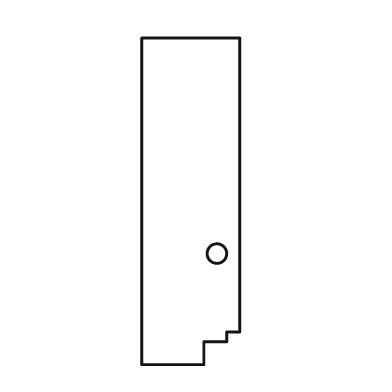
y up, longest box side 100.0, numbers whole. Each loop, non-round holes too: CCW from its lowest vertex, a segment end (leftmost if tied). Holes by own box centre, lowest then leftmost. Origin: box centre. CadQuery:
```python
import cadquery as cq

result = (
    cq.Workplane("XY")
    .moveTo(-15.0, -50.0)
    .lineTo(4.0, -50.0)
    .lineTo(4.0, -43.0)
    .lineTo(11.0, -43.0)
    .lineTo(11.0, -40.0)
    .lineTo(15.0, -40.0)
    .lineTo(15.0, 50.0)
    .lineTo(-15.0, 50.0)
    .close()
    .moveTo(8.0, -16.0)
    .circle(3.0)
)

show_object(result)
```